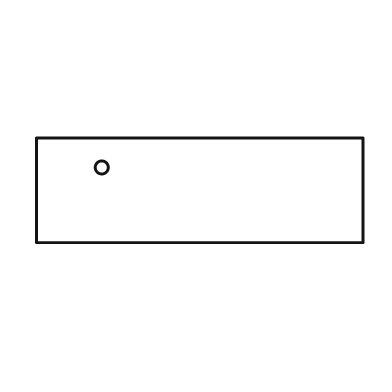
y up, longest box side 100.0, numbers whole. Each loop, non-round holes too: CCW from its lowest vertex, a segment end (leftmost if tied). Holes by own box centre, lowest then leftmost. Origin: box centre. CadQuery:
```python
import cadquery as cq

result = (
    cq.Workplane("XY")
    .moveTo(-50.0, -16.0)
    .lineTo(50.0, -16.0)
    .lineTo(50.0, 16.0)
    .lineTo(-50.0, 16.0)
    .close()
    .moveTo(-30.0, 7.0)
    .circle(2.0)
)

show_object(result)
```